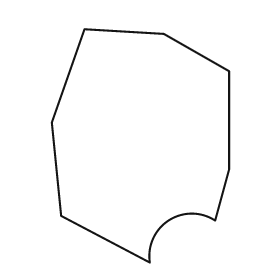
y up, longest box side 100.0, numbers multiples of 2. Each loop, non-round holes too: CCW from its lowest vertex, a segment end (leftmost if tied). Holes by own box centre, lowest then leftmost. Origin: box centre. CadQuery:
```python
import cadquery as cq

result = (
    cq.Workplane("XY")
    .moveTo(4.0, -50.0)
    .threePointArc((12.0, -32.0), (32.0, -32.0))
    .lineTo(38.0, -10.0)
    .lineTo(38.0, 32.0)
    .lineTo(10.0, 48.0)
    .lineTo(-24.0, 50.0)
    .lineTo(-38.0, 10.0)
    .lineTo(-34.0, -30.0)
    .close()
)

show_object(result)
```